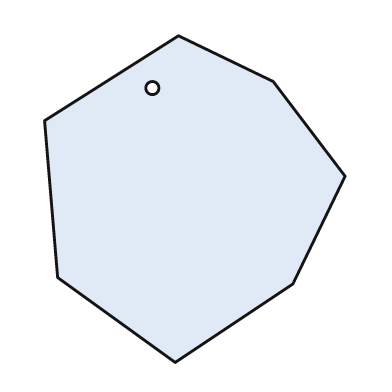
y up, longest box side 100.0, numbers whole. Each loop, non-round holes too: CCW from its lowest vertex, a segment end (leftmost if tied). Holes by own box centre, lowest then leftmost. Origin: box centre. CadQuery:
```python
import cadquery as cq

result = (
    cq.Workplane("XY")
    .moveTo(-6.0, -50.0)
    .lineTo(30.0, -26.0)
    .lineTo(46.0, 7.0)
    .lineTo(24.0, 36.0)
    .lineTo(-5.0, 50.0)
    .lineTo(-46.0, 24.0)
    .lineTo(-42.0, -24.0)
    .close()
    .moveTo(-13.0, 34.0)
    .circle(2.0)
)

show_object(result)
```